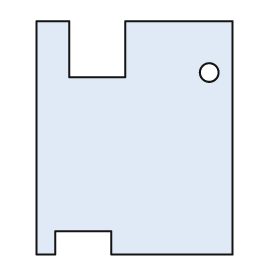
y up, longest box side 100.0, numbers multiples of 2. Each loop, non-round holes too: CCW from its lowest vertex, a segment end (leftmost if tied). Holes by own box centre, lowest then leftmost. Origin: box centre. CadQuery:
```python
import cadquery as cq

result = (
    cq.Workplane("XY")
    .moveTo(-42.0, -50.0)
    .lineTo(-34.0, -50.0)
    .lineTo(-34.0, -40.0)
    .lineTo(-10.0, -40.0)
    .lineTo(-10.0, -50.0)
    .lineTo(42.0, -50.0)
    .lineTo(42.0, 50.0)
    .lineTo(-4.0, 50.0)
    .lineTo(-4.0, 26.0)
    .lineTo(-28.0, 26.0)
    .lineTo(-28.0, 50.0)
    .lineTo(-42.0, 50.0)
    .close()
    .moveTo(32.0, 28.0)
    .circle(4.0)
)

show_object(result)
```